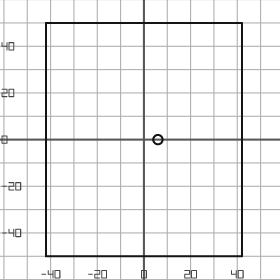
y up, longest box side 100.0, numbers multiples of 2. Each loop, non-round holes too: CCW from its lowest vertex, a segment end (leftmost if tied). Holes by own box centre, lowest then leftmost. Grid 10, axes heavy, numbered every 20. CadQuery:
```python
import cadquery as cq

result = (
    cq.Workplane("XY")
    .moveTo(-42.0, -50.0)
    .lineTo(42.0, -50.0)
    .lineTo(42.0, 50.0)
    .lineTo(-42.0, 50.0)
    .close()
    .moveTo(6.0, 0.0)
    .circle(2.0)
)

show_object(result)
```